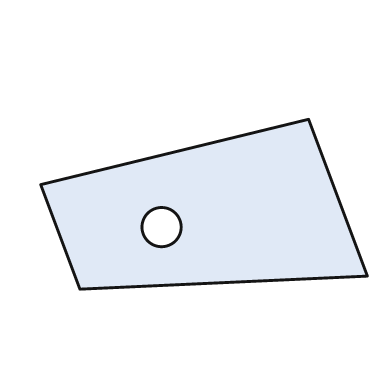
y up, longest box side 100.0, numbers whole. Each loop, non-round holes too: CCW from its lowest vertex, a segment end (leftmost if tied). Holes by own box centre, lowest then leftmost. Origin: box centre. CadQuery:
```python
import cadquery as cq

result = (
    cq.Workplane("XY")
    .moveTo(-38.0, -26.0)
    .lineTo(50.0, -22.0)
    .lineTo(32.0, 26.0)
    .lineTo(-50.0, 6.0)
    .close()
    .moveTo(-13.0, -7.0)
    .circle(6.0)
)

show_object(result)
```